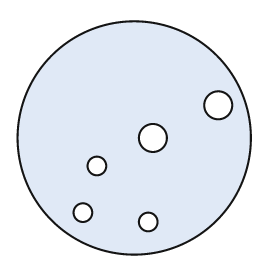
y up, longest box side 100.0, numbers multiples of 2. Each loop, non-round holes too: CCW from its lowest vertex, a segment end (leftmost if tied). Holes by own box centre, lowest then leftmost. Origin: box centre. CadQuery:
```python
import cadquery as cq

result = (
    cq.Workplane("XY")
    .moveTo(0.0, 0.0)
    .circle(50.0)
    .moveTo(6.0, -36.0)
    .circle(4.0)
    .moveTo(-22.0, -32.0)
    .circle(4.0)
    .moveTo(-16.0, -12.0)
    .circle(4.0)
    .moveTo(8.0, 0.0)
    .circle(6.0)
    .moveTo(36.0, 14.0)
    .circle(6.0)
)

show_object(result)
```